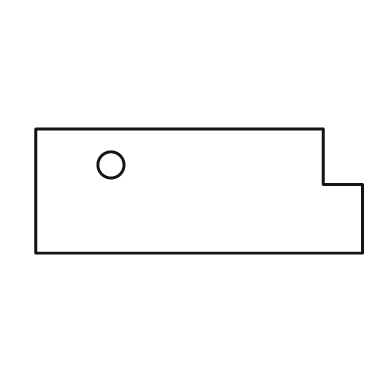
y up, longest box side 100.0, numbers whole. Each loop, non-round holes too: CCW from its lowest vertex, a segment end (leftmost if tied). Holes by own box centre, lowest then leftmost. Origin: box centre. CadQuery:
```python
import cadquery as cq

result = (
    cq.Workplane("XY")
    .moveTo(-50.0, -19.0)
    .lineTo(50.0, -19.0)
    .lineTo(50.0, 2.0)
    .lineTo(38.0, 2.0)
    .lineTo(38.0, 19.0)
    .lineTo(-50.0, 19.0)
    .close()
    .moveTo(-27.0, 8.0)
    .circle(4.0)
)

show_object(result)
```